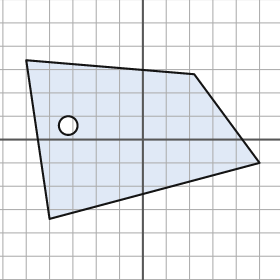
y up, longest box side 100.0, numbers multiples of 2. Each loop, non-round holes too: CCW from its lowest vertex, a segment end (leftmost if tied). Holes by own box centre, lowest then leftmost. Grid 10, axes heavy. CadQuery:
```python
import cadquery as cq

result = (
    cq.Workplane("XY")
    .moveTo(-40.0, -34.0)
    .lineTo(50.0, -10.0)
    .lineTo(22.0, 28.0)
    .lineTo(-50.0, 34.0)
    .close()
    .moveTo(-32.0, 6.0)
    .circle(4.0)
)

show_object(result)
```